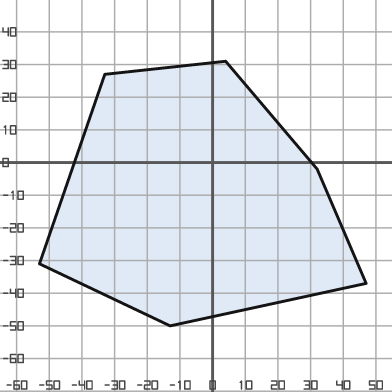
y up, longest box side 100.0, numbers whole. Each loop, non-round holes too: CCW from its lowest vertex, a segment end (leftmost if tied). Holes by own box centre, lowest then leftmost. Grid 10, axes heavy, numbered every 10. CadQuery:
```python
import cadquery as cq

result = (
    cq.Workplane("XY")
    .moveTo(-13.0, -50.0)
    .lineTo(47.0, -37.0)
    .lineTo(32.0, -2.0)
    .lineTo(4.0, 31.0)
    .lineTo(-33.0, 27.0)
    .lineTo(-53.0, -31.0)
    .close()
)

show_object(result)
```